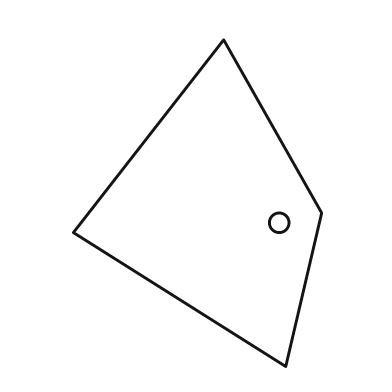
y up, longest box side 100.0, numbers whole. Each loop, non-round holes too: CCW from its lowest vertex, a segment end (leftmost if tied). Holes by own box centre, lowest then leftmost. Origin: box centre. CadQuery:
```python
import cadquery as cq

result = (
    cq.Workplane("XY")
    .moveTo(27.0, -50.0)
    .lineTo(38.0, -3.0)
    .lineTo(8.0, 50.0)
    .lineTo(-38.0, -9.0)
    .close()
    .moveTo(25.0, -6.0)
    .circle(3.0)
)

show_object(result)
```